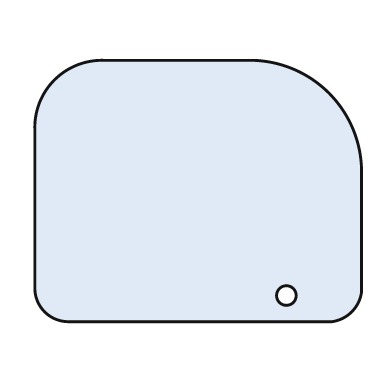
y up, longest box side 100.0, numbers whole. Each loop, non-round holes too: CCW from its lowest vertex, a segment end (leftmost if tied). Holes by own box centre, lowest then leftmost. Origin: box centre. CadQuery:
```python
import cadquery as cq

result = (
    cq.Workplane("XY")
    .moveTo(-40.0, -40.0)
    .lineTo(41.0, -40.0)
    .threePointArc((47.0, -37.0), (50.0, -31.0))
    .lineTo(50.0, 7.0)
    .threePointArc((40.0, 30.0), (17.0, 40.0))
    .lineTo(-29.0, 40.0)
    .threePointArc((-44.0, 34.0), (-50.0, 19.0))
    .lineTo(-50.0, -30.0)
    .threePointArc((-47.0, -37.0), (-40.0, -40.0))
    .close()
    .moveTo(27.0, -32.0)
    .circle(3.0)
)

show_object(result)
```